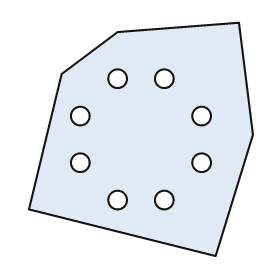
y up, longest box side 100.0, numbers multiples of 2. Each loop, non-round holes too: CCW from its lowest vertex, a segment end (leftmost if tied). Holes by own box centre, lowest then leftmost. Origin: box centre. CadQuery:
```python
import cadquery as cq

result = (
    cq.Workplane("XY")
    .moveTo(32.0, -50.0)
    .lineTo(48.0, 2.0)
    .lineTo(42.0, 50.0)
    .lineTo(-10.0, 46.0)
    .lineTo(-34.0, 28.0)
    .lineTo(-48.0, -30.0)
    .close()
    .moveTo(-10.0, -26.0)
    .circle(4.0)
    .moveTo(10.0, -26.0)
    .circle(4.0)
    .moveTo(-26.0, -10.0)
    .circle(4.0)
    .moveTo(26.0, -10.0)
    .circle(4.0)
    .moveTo(-26.0, 10.0)
    .circle(4.0)
    .moveTo(26.0, 10.0)
    .circle(4.0)
    .moveTo(-10.0, 26.0)
    .circle(4.0)
    .moveTo(10.0, 26.0)
    .circle(4.0)
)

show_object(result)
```